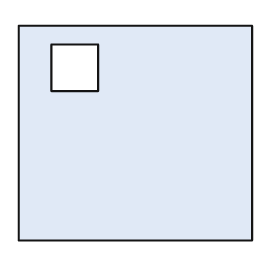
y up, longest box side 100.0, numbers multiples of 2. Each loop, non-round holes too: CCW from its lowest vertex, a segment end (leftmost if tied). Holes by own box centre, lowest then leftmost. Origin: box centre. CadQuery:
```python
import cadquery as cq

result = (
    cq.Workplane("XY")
    .moveTo(-50.0, -46.0)
    .lineTo(50.0, -46.0)
    .lineTo(50.0, 46.0)
    .lineTo(-50.0, 46.0)
    .close()
    .moveTo(-36.0, 18.0)
    .lineTo(-16.0, 18.0)
    .lineTo(-16.0, 38.0)
    .lineTo(-36.0, 38.0)
    .close()
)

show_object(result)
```